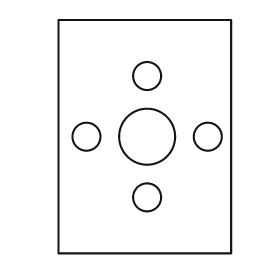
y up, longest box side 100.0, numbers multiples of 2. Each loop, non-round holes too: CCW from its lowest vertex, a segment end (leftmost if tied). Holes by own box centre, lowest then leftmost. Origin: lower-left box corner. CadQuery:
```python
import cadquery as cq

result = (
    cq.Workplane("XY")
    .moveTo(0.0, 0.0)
    .lineTo(74.0, 0.0)
    .lineTo(74.0, 100.0)
    .lineTo(0.0, 100.0)
    .close()
    .moveTo(38.0, 24.0)
    .circle(6.0)
    .moveTo(12.0, 50.0)
    .circle(6.0)
    .moveTo(38.0, 50.0)
    .circle(12.0)
    .moveTo(64.0, 50.0)
    .circle(6.0)
    .moveTo(38.0, 76.0)
    .circle(6.0)
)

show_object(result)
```